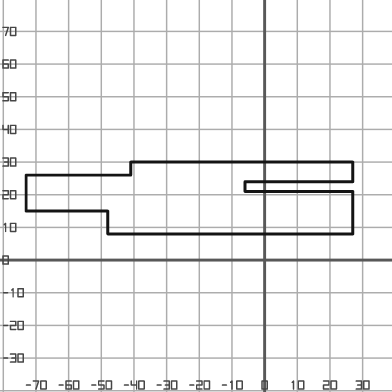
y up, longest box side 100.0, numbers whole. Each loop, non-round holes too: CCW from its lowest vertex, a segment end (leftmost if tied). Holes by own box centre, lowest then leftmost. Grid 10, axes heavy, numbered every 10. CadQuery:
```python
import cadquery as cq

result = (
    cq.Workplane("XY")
    .moveTo(-48.0, 8.0)
    .lineTo(27.0, 8.0)
    .lineTo(27.0, 21.0)
    .lineTo(-6.0, 21.0)
    .lineTo(-6.0, 24.0)
    .lineTo(27.0, 24.0)
    .lineTo(27.0, 30.0)
    .lineTo(-41.0, 30.0)
    .lineTo(-41.0, 26.0)
    .lineTo(-73.0, 26.0)
    .lineTo(-73.0, 15.0)
    .lineTo(-48.0, 15.0)
    .close()
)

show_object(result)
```